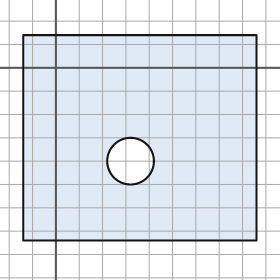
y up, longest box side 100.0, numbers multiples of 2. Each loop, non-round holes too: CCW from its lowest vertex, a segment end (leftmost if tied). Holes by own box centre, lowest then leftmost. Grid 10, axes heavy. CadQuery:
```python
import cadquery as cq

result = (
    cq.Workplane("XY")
    .moveTo(-14.0, -74.0)
    .lineTo(86.0, -74.0)
    .lineTo(86.0, 14.0)
    .lineTo(-14.0, 14.0)
    .close()
    .moveTo(32.0, -40.0)
    .circle(10.0)
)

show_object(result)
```